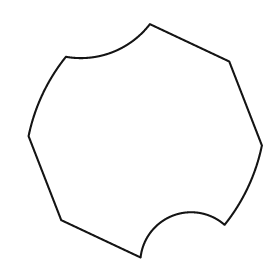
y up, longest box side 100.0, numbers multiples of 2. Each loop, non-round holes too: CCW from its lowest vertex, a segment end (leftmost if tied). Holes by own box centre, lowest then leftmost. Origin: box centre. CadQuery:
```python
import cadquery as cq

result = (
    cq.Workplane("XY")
    .moveTo(-2.0, -50.0)
    .threePointArc((12.0, -32.0), (34.0, -36.0))
    .threePointArc((44.0, -20.0), (50.0, -2.0))
    .lineTo(36.0, 34.0)
    .lineTo(2.0, 50.0)
    .threePointArc((-14.0, 38.0), (-34.0, 36.0))
    .threePointArc((-44.0, 20.0), (-50.0, 2.0))
    .lineTo(-36.0, -34.0)
    .close()
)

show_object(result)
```